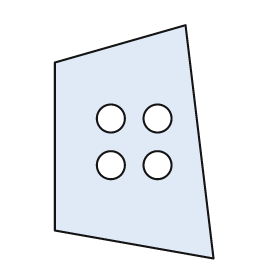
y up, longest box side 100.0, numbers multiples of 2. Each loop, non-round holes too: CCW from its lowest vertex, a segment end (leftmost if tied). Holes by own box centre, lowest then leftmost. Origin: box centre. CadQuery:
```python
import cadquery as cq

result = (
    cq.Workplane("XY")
    .moveTo(34.0, -50.0)
    .lineTo(22.0, 50.0)
    .lineTo(-34.0, 34.0)
    .lineTo(-34.0, -38.0)
    .close()
    .moveTo(-10.0, -10.0)
    .circle(6.0)
    .moveTo(10.0, -10.0)
    .circle(6.0)
    .moveTo(-10.0, 10.0)
    .circle(6.0)
    .moveTo(10.0, 10.0)
    .circle(6.0)
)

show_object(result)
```